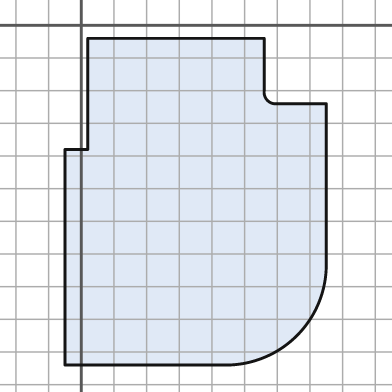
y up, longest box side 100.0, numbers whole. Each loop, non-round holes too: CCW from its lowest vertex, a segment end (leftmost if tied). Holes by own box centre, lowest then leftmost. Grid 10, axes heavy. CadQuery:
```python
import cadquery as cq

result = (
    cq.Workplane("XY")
    .moveTo(-5.0, -104.0)
    .lineTo(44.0, -104.0)
    .threePointArc((66.0, -95.0), (75.0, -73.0))
    .lineTo(75.0, -24.0)
    .lineTo(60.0, -24.0)
    .threePointArc((57.0, -23.0), (56.0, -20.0))
    .lineTo(56.0, -4.0)
    .lineTo(2.0, -4.0)
    .lineTo(2.0, -38.0)
    .lineTo(-5.0, -38.0)
    .close()
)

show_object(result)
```